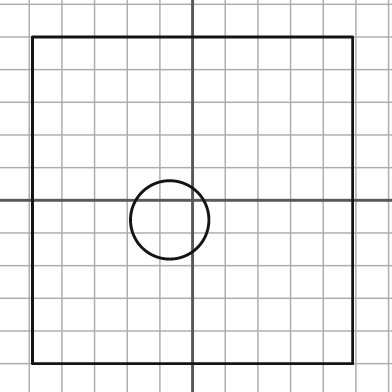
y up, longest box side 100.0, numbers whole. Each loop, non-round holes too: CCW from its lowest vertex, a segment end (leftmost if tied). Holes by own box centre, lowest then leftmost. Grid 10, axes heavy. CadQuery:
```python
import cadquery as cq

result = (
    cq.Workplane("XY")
    .moveTo(-49.0, -50.0)
    .lineTo(49.0, -50.0)
    .lineTo(49.0, 50.0)
    .lineTo(-49.0, 50.0)
    .close()
    .moveTo(-7.0, -6.0)
    .circle(12.0)
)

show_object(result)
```